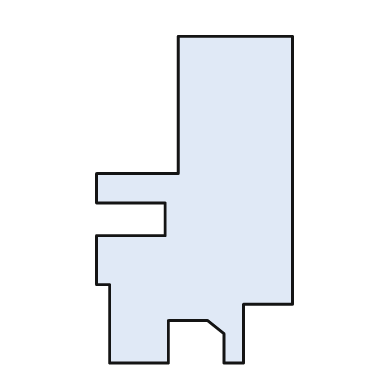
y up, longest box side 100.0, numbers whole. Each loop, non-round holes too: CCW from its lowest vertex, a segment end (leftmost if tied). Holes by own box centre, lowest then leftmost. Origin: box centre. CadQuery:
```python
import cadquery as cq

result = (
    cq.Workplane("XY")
    .moveTo(-26.0, -50.0)
    .lineTo(-8.0, -50.0)
    .lineTo(-8.0, -37.0)
    .lineTo(4.0, -37.0)
    .lineTo(9.0, -41.0)
    .lineTo(9.0, -50.0)
    .lineTo(15.0, -50.0)
    .lineTo(15.0, -32.0)
    .lineTo(30.0, -32.0)
    .lineTo(30.0, 50.0)
    .lineTo(-5.0, 50.0)
    .lineTo(-5.0, 8.0)
    .lineTo(-30.0, 8.0)
    .lineTo(-30.0, -1.0)
    .lineTo(-9.0, -1.0)
    .lineTo(-9.0, -11.0)
    .lineTo(-30.0, -11.0)
    .lineTo(-30.0, -26.0)
    .lineTo(-26.0, -26.0)
    .close()
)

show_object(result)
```